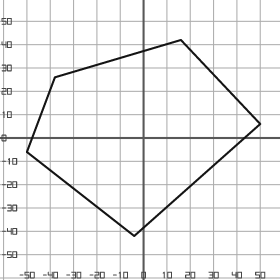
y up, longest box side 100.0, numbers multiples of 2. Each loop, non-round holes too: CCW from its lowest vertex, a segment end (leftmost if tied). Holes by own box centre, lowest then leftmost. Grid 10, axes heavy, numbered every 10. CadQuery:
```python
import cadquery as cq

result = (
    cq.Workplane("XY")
    .moveTo(-4.0, -42.0)
    .lineTo(50.0, 6.0)
    .lineTo(16.0, 42.0)
    .lineTo(-38.0, 26.0)
    .lineTo(-50.0, -6.0)
    .close()
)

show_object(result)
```